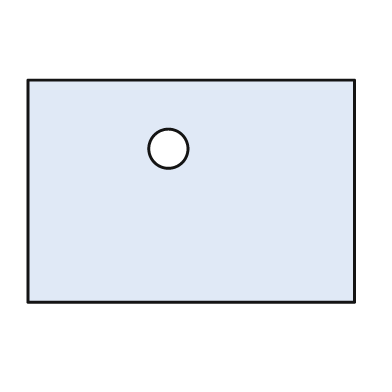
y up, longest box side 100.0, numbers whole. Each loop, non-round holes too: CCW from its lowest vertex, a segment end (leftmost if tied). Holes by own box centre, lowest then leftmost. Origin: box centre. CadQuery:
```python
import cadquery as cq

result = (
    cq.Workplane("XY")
    .moveTo(-50.0, -34.0)
    .lineTo(50.0, -34.0)
    .lineTo(50.0, 34.0)
    .lineTo(-50.0, 34.0)
    .close()
    .moveTo(-7.0, 13.0)
    .circle(6.0)
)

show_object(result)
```